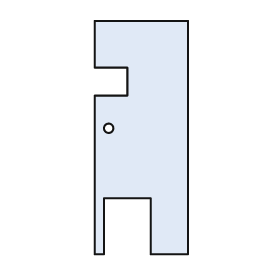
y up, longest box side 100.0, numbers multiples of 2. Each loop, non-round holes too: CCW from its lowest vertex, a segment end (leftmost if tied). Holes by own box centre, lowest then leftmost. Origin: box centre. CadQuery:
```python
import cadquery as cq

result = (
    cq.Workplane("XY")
    .moveTo(-20.0, -50.0)
    .lineTo(-16.0, -50.0)
    .lineTo(-16.0, -26.0)
    .lineTo(4.0, -26.0)
    .lineTo(4.0, -50.0)
    .lineTo(20.0, -50.0)
    .lineTo(20.0, 50.0)
    .lineTo(-20.0, 50.0)
    .lineTo(-20.0, 30.0)
    .lineTo(-6.0, 30.0)
    .lineTo(-6.0, 18.0)
    .lineTo(-20.0, 18.0)
    .close()
    .moveTo(-14.0, 4.0)
    .circle(2.0)
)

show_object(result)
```